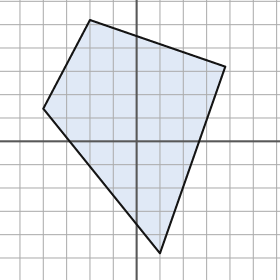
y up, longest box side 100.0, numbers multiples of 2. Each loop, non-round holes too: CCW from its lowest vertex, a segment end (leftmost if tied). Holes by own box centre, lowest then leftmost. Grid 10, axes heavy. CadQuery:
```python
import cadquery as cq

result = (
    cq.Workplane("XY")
    .moveTo(10.0, -48.0)
    .lineTo(38.0, 32.0)
    .lineTo(-20.0, 52.0)
    .lineTo(-40.0, 14.0)
    .close()
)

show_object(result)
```